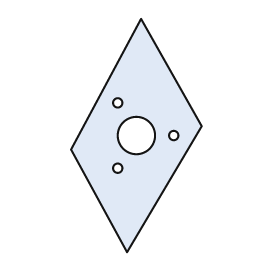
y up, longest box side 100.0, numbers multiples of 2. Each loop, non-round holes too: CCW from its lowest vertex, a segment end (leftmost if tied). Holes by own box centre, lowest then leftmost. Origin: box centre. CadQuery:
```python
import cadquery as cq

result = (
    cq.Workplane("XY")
    .moveTo(-4.0, -50.0)
    .lineTo(28.0, 4.0)
    .lineTo(2.0, 50.0)
    .lineTo(-28.0, -6.0)
    .close()
    .moveTo(-8.0, -14.0)
    .circle(2.0)
    .moveTo(0.0, 0.0)
    .circle(8.0)
    .moveTo(16.0, 0.0)
    .circle(2.0)
    .moveTo(-8.0, 14.0)
    .circle(2.0)
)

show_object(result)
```